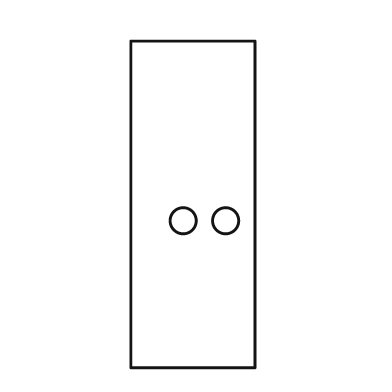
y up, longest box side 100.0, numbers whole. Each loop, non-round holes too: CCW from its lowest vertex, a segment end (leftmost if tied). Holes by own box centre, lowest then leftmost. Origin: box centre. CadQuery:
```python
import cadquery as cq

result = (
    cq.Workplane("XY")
    .moveTo(-19.0, -50.0)
    .lineTo(19.0, -50.0)
    .lineTo(19.0, 50.0)
    .lineTo(-19.0, 50.0)
    .close()
    .moveTo(-3.0, -5.0)
    .circle(4.0)
    .moveTo(10.0, -5.0)
    .circle(4.0)
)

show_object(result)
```